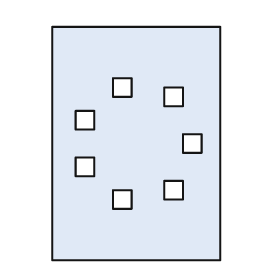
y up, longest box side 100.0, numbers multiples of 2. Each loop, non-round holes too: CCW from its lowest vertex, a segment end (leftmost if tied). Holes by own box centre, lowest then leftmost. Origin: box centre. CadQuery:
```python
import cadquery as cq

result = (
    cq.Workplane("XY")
    .moveTo(-36.0, -50.0)
    .lineTo(36.0, -50.0)
    .lineTo(36.0, 50.0)
    .lineTo(-36.0, 50.0)
    .close()
    .moveTo(-10.0, -28.0)
    .lineTo(-2.0, -28.0)
    .lineTo(-2.0, -20.0)
    .lineTo(-10.0, -20.0)
    .close()
    .moveTo(12.0, -24.0)
    .lineTo(20.0, -24.0)
    .lineTo(20.0, -16.0)
    .lineTo(12.0, -16.0)
    .close()
    .moveTo(-26.0, -14.0)
    .lineTo(-18.0, -14.0)
    .lineTo(-18.0, -6.0)
    .lineTo(-26.0, -6.0)
    .close()
    .moveTo(20.0, -4.0)
    .lineTo(28.0, -4.0)
    .lineTo(28.0, 4.0)
    .lineTo(20.0, 4.0)
    .close()
    .moveTo(-26.0, 6.0)
    .lineTo(-18.0, 6.0)
    .lineTo(-18.0, 14.0)
    .lineTo(-26.0, 14.0)
    .close()
    .moveTo(12.0, 16.0)
    .lineTo(20.0, 16.0)
    .lineTo(20.0, 24.0)
    .lineTo(12.0, 24.0)
    .close()
    .moveTo(-10.0, 20.0)
    .lineTo(-2.0, 20.0)
    .lineTo(-2.0, 28.0)
    .lineTo(-10.0, 28.0)
    .close()
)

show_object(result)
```